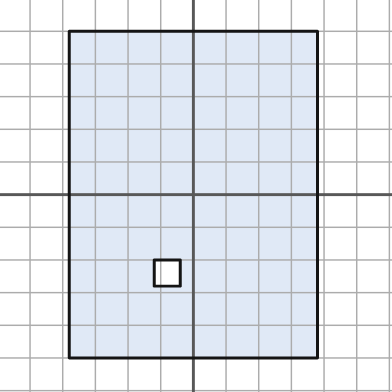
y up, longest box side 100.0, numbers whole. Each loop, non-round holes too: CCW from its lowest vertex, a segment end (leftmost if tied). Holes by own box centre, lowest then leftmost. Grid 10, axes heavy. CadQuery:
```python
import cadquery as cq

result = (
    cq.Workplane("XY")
    .moveTo(-38.0, -50.0)
    .lineTo(38.0, -50.0)
    .lineTo(38.0, 50.0)
    .lineTo(-38.0, 50.0)
    .close()
    .moveTo(-12.0, -28.0)
    .lineTo(-4.0, -28.0)
    .lineTo(-4.0, -20.0)
    .lineTo(-12.0, -20.0)
    .close()
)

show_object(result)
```